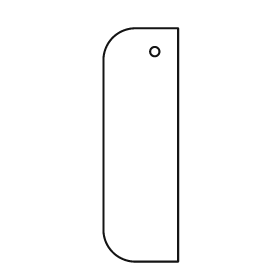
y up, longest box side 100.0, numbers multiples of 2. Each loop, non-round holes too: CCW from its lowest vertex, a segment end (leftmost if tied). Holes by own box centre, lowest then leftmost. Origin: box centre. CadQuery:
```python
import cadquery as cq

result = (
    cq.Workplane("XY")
    .moveTo(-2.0, -50.0)
    .lineTo(16.0, -50.0)
    .lineTo(16.0, 50.0)
    .lineTo(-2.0, 50.0)
    .threePointArc((-12.0, 46.0), (-16.0, 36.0))
    .lineTo(-16.0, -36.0)
    .threePointArc((-12.0, -46.0), (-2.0, -50.0))
    .close()
    .moveTo(6.0, 40.0)
    .circle(2.0)
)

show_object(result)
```